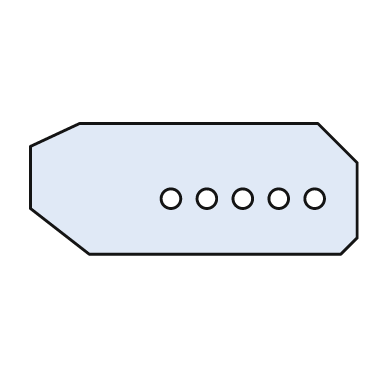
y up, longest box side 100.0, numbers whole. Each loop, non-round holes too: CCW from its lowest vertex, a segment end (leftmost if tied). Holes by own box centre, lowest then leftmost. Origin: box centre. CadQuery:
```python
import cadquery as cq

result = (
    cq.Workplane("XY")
    .moveTo(-32.0, -20.0)
    .lineTo(45.0, -20.0)
    .lineTo(50.0, -15.0)
    .lineTo(50.0, 8.0)
    .lineTo(38.0, 20.0)
    .lineTo(-35.0, 20.0)
    .lineTo(-50.0, 13.0)
    .lineTo(-50.0, -6.0)
    .close()
    .moveTo(-7.0, -3.0)
    .circle(3.0)
    .moveTo(4.0, -3.0)
    .circle(3.0)
    .moveTo(15.0, -3.0)
    .circle(3.0)
    .moveTo(26.0, -3.0)
    .circle(3.0)
    .moveTo(37.0, -3.0)
    .circle(3.0)
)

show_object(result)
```